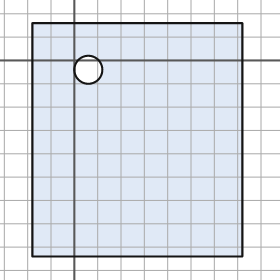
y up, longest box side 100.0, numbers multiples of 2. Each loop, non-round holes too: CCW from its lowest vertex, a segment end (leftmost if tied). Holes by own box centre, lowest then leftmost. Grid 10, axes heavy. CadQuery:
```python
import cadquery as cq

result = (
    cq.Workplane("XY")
    .moveTo(-18.0, -84.0)
    .lineTo(72.0, -84.0)
    .lineTo(72.0, 16.0)
    .lineTo(-18.0, 16.0)
    .close()
    .moveTo(6.0, -4.0)
    .circle(6.0)
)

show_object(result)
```